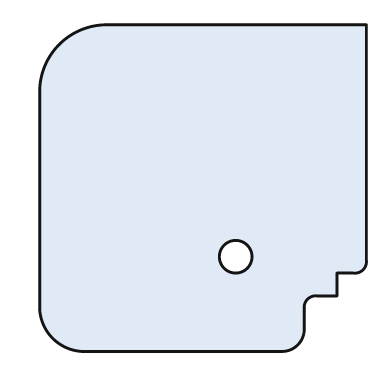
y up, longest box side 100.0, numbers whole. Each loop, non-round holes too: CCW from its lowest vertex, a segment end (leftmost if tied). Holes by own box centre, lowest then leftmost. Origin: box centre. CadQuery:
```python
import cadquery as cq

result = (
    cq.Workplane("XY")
    .moveTo(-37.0, -50.0)
    .lineTo(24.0, -50.0)
    .threePointArc((29.0, -48.0), (31.0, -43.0))
    .lineTo(31.0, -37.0)
    .threePointArc((32.0, -34.0), (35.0, -33.0))
    .lineTo(41.0, -33.0)
    .lineTo(41.0, -26.0)
    .lineTo(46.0, -26.0)
    .threePointArc((49.0, -25.0), (50.0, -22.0))
    .lineTo(50.0, 50.0)
    .lineTo(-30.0, 50.0)
    .threePointArc((-44.0, 44.0), (-50.0, 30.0))
    .lineTo(-50.0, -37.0)
    .threePointArc((-46.0, -46.0), (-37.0, -50.0))
    .close()
    .moveTo(10.0, -21.0)
    .circle(5.0)
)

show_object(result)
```